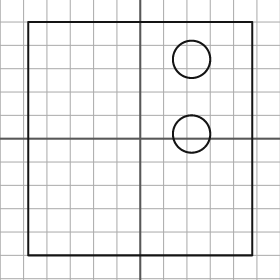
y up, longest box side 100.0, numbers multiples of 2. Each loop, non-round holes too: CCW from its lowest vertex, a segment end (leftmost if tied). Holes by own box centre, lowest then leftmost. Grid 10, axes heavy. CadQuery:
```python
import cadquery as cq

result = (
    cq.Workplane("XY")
    .moveTo(-48.0, -50.0)
    .lineTo(48.0, -50.0)
    .lineTo(48.0, 50.0)
    .lineTo(-48.0, 50.0)
    .close()
    .moveTo(22.0, 2.0)
    .circle(8.0)
    .moveTo(22.0, 34.0)
    .circle(8.0)
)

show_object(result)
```